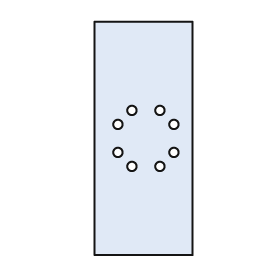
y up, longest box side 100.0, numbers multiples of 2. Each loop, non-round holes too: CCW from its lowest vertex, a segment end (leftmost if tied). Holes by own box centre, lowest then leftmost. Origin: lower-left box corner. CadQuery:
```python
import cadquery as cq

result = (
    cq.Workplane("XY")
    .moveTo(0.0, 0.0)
    .lineTo(42.0, 0.0)
    .lineTo(42.0, 100.0)
    .lineTo(0.0, 100.0)
    .close()
    .moveTo(16.0, 38.0)
    .circle(2.0)
    .moveTo(28.0, 38.0)
    .circle(2.0)
    .moveTo(10.0, 44.0)
    .circle(2.0)
    .moveTo(34.0, 44.0)
    .circle(2.0)
    .moveTo(10.0, 56.0)
    .circle(2.0)
    .moveTo(34.0, 56.0)
    .circle(2.0)
    .moveTo(16.0, 62.0)
    .circle(2.0)
    .moveTo(28.0, 62.0)
    .circle(2.0)
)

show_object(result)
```